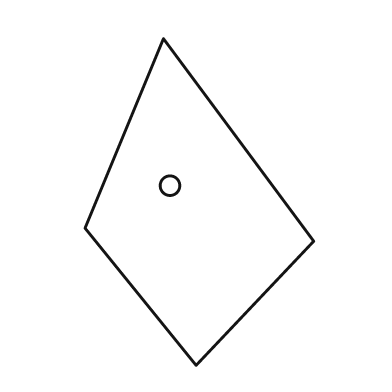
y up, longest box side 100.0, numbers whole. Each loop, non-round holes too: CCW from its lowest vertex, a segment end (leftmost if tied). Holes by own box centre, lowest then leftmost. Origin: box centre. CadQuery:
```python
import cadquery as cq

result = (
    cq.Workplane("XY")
    .moveTo(-1.0, -50.0)
    .lineTo(35.0, -12.0)
    .lineTo(-11.0, 50.0)
    .lineTo(-35.0, -8.0)
    .close()
    .moveTo(-9.0, 5.0)
    .circle(3.0)
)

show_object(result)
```